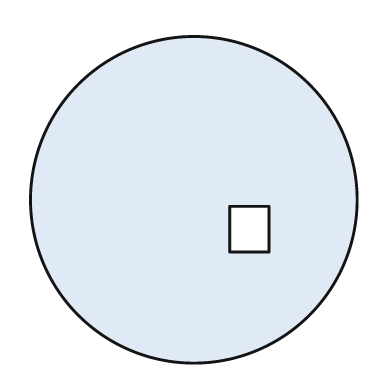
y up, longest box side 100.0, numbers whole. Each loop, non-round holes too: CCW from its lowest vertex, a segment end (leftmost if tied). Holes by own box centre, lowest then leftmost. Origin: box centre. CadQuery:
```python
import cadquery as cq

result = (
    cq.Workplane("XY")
    .moveTo(0.0, 0.0)
    .circle(50.0)
    .moveTo(11.0, -16.0)
    .lineTo(23.0, -16.0)
    .lineTo(23.0, -2.0)
    .lineTo(11.0, -2.0)
    .close()
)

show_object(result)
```